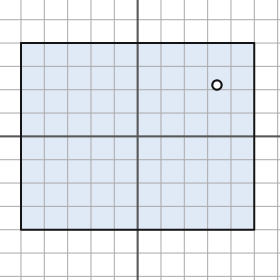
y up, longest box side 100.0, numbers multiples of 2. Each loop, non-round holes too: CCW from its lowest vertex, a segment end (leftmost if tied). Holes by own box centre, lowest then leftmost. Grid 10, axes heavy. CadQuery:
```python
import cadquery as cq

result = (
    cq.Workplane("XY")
    .moveTo(-50.0, -40.0)
    .lineTo(50.0, -40.0)
    .lineTo(50.0, 40.0)
    .lineTo(-50.0, 40.0)
    .close()
    .moveTo(34.0, 22.0)
    .circle(2.0)
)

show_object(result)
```